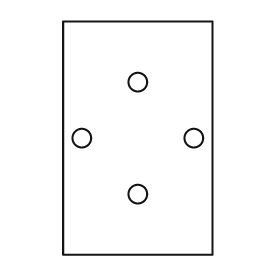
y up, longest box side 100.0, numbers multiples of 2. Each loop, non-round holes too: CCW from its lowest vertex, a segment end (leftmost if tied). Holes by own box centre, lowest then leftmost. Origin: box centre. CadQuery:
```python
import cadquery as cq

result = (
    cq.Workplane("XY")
    .moveTo(-32.0, -50.0)
    .lineTo(32.0, -50.0)
    .lineTo(32.0, 50.0)
    .lineTo(-32.0, 50.0)
    .close()
    .moveTo(0.0, -24.0)
    .circle(4.0)
    .moveTo(-24.0, 0.0)
    .circle(4.0)
    .moveTo(24.0, 0.0)
    .circle(4.0)
    .moveTo(0.0, 24.0)
    .circle(4.0)
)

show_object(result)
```